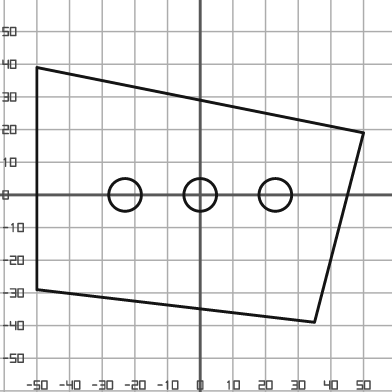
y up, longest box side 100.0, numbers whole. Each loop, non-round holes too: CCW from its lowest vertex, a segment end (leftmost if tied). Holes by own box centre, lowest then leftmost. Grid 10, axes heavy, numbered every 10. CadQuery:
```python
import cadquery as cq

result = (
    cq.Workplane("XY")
    .moveTo(35.0, -39.0)
    .lineTo(50.0, 19.0)
    .lineTo(-50.0, 39.0)
    .lineTo(-50.0, -29.0)
    .close()
    .moveTo(-23.0, 0.0)
    .circle(5.0)
    .moveTo(0.0, 0.0)
    .circle(5.0)
    .moveTo(23.0, 0.0)
    .circle(5.0)
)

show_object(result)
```